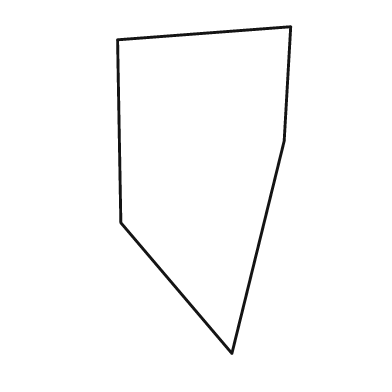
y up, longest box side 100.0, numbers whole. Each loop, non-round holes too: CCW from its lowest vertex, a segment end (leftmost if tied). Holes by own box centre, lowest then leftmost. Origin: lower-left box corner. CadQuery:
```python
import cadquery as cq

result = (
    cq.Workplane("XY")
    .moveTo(35.0, 0.0)
    .lineTo(51.0, 65.0)
    .lineTo(53.0, 100.0)
    .lineTo(0.0, 96.0)
    .lineTo(1.0, 40.0)
    .close()
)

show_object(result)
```